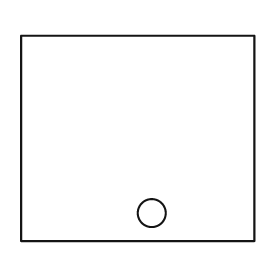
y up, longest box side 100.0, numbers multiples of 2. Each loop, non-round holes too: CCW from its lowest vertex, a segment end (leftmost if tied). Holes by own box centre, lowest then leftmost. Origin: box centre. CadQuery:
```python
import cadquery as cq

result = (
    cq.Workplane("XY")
    .moveTo(-50.0, -44.0)
    .lineTo(50.0, -44.0)
    .lineTo(50.0, 44.0)
    .lineTo(-50.0, 44.0)
    .close()
    .moveTo(6.0, -32.0)
    .circle(6.0)
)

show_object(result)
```